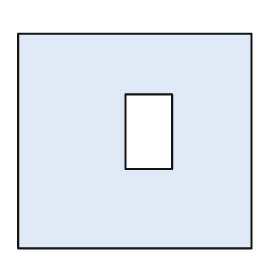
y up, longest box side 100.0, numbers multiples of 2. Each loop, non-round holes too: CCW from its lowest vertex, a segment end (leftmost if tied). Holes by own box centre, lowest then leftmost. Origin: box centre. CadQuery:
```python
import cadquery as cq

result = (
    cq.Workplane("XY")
    .moveTo(-50.0, -46.0)
    .lineTo(50.0, -46.0)
    .lineTo(50.0, 46.0)
    .lineTo(-50.0, 46.0)
    .close()
    .moveTo(-4.0, -12.0)
    .lineTo(16.0, -12.0)
    .lineTo(16.0, 20.0)
    .lineTo(-4.0, 20.0)
    .close()
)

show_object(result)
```